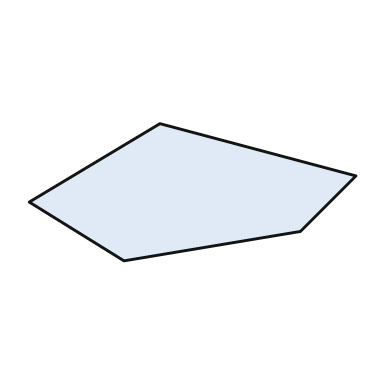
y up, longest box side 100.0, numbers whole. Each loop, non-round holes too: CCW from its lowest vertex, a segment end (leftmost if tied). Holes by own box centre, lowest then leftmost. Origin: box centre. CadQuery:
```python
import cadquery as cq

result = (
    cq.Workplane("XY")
    .moveTo(-21.0, -21.0)
    .lineTo(33.0, -12.0)
    .lineTo(50.0, 5.0)
    .lineTo(-10.0, 21.0)
    .lineTo(-50.0, -3.0)
    .close()
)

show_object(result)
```